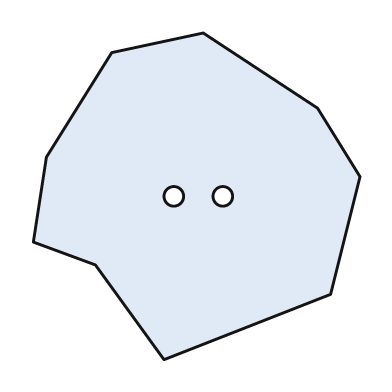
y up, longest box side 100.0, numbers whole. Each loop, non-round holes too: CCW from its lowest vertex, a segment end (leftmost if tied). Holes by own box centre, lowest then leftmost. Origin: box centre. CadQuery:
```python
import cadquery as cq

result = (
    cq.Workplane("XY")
    .moveTo(-10.0, -50.0)
    .lineTo(41.0, -30.0)
    .lineTo(50.0, 6.0)
    .lineTo(37.0, 27.0)
    .lineTo(2.0, 50.0)
    .lineTo(-26.0, 44.0)
    .lineTo(-46.0, 12.0)
    .lineTo(-50.0, -14.0)
    .lineTo(-31.0, -21.0)
    .close()
    .moveTo(-7.0, 0.0)
    .circle(3.0)
    .moveTo(8.0, 0.0)
    .circle(3.0)
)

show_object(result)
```